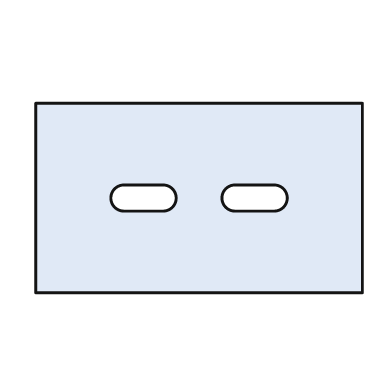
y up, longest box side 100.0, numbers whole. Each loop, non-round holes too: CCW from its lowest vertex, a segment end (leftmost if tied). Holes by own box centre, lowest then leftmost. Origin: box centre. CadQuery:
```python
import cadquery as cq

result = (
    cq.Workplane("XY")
    .moveTo(-50.0, -29.0)
    .lineTo(50.0, -29.0)
    .lineTo(50.0, 29.0)
    .lineTo(-50.0, 29.0)
    .close()
    .moveTo(-23.0, -4.0)
    .lineTo(-11.0, -4.0)
    .threePointArc((-7.0, 0.0), (-11.0, 4.0))
    .lineTo(-23.0, 4.0)
    .threePointArc((-27.0, 0.0), (-23.0, -4.0))
    .close()
    .moveTo(11.0, -4.0)
    .lineTo(23.0, -4.0)
    .threePointArc((27.0, 0.0), (23.0, 4.0))
    .lineTo(11.0, 4.0)
    .threePointArc((7.0, 0.0), (11.0, -4.0))
    .close()
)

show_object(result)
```